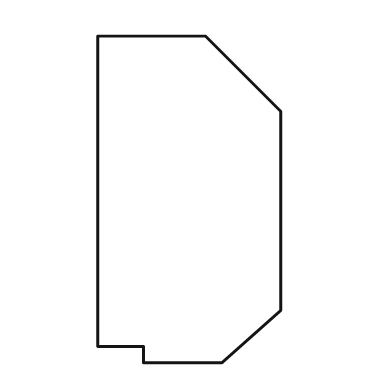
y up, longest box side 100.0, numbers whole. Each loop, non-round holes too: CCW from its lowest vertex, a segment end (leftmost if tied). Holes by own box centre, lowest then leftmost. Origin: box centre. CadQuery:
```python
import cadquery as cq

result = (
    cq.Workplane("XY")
    .moveTo(-14.0, -50.0)
    .lineTo(10.0, -50.0)
    .lineTo(28.0, -34.0)
    .lineTo(28.0, 27.0)
    .lineTo(5.0, 50.0)
    .lineTo(-28.0, 50.0)
    .lineTo(-28.0, -45.0)
    .lineTo(-14.0, -45.0)
    .close()
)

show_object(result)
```